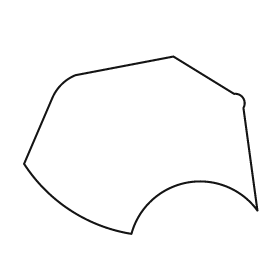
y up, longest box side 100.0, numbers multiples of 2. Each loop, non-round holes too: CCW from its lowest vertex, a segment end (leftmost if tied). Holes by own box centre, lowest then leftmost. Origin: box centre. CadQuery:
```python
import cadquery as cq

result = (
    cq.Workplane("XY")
    .moveTo(-4.0, -38.0)
    .threePointArc((20.0, -16.0), (50.0, -28.0))
    .lineTo(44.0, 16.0)
    .threePointArc((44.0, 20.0), (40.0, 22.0))
    .lineTo(14.0, 38.0)
    .lineTo(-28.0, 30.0)
    .threePointArc((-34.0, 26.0), (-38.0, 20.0))
    .lineTo(-50.0, -8.0)
    .threePointArc((-30.0, -28.0), (-4.0, -38.0))
    .close()
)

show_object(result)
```